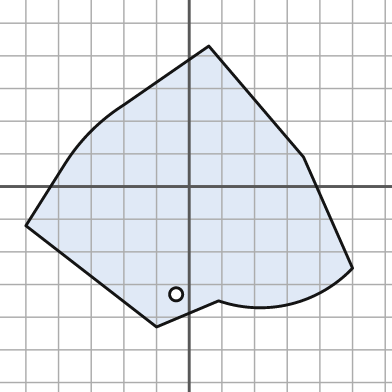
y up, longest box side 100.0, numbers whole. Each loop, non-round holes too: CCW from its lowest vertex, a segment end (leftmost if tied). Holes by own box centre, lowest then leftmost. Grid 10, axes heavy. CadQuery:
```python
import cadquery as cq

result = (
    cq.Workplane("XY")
    .moveTo(-10.0, -43.0)
    .lineTo(9.0, -35.0)
    .threePointArc((31.0, -36.0), (50.0, -25.0))
    .lineTo(35.0, 9.0)
    .lineTo(6.0, 43.0)
    .lineTo(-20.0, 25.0)
    .threePointArc((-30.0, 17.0), (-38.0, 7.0))
    .lineTo(-50.0, -12.0)
    .close()
    .moveTo(-4.0, -33.0)
    .circle(2.0)
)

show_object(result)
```